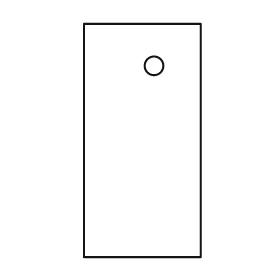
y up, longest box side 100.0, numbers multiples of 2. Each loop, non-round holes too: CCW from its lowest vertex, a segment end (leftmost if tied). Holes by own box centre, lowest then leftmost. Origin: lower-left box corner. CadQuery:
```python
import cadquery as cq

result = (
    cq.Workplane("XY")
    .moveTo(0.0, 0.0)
    .lineTo(50.0, 0.0)
    .lineTo(50.0, 100.0)
    .lineTo(0.0, 100.0)
    .close()
    .moveTo(30.0, 82.0)
    .circle(4.0)
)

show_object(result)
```